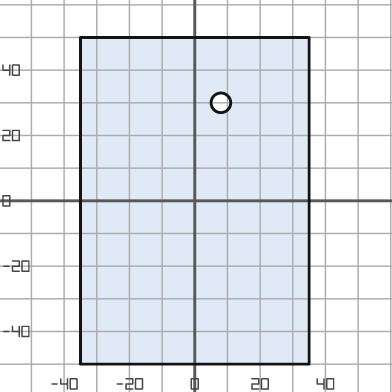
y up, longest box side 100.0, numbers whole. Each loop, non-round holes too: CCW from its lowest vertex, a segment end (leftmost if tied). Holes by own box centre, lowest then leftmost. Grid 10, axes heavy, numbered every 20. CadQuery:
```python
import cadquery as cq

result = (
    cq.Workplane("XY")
    .moveTo(-35.0, -50.0)
    .lineTo(35.0, -50.0)
    .lineTo(35.0, 50.0)
    .lineTo(-35.0, 50.0)
    .close()
    .moveTo(8.0, 30.0)
    .circle(3.0)
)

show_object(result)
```